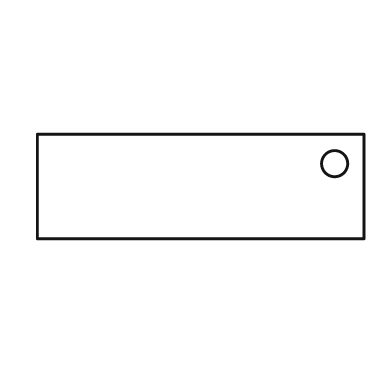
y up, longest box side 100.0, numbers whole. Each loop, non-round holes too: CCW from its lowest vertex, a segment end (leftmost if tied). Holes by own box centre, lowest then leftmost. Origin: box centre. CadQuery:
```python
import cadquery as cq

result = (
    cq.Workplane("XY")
    .moveTo(-50.0, -16.0)
    .lineTo(50.0, -16.0)
    .lineTo(50.0, 16.0)
    .lineTo(-50.0, 16.0)
    .close()
    .moveTo(41.0, 7.0)
    .circle(4.0)
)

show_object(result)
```